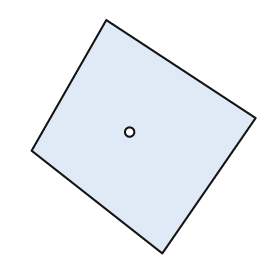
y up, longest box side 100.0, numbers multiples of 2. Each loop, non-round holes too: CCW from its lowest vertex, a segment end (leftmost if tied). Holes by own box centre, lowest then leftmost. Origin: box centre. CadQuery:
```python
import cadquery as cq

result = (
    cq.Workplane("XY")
    .moveTo(8.0, -50.0)
    .lineTo(48.0, 8.0)
    .lineTo(-16.0, 50.0)
    .lineTo(-48.0, -6.0)
    .close()
    .moveTo(-6.0, 2.0)
    .circle(2.0)
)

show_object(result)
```